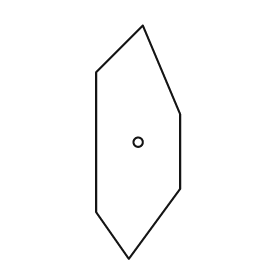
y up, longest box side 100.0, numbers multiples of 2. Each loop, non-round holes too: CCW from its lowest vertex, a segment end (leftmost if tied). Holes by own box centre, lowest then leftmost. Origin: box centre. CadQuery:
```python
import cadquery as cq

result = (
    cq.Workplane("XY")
    .moveTo(-4.0, -50.0)
    .lineTo(18.0, -20.0)
    .lineTo(18.0, 12.0)
    .lineTo(2.0, 50.0)
    .lineTo(-18.0, 30.0)
    .lineTo(-18.0, -30.0)
    .close()
    .moveTo(0.0, 0.0)
    .circle(2.0)
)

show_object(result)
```